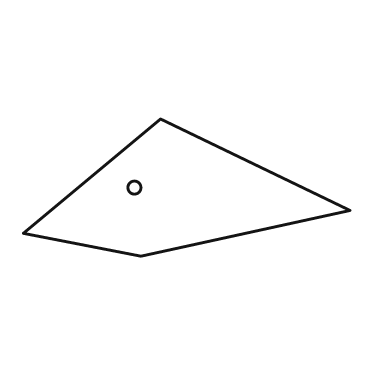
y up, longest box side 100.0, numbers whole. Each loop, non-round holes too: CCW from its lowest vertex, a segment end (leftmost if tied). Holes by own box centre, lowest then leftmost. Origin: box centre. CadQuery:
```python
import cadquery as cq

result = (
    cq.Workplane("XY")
    .moveTo(-14.0, -21.0)
    .lineTo(50.0, -7.0)
    .lineTo(-8.0, 21.0)
    .lineTo(-50.0, -14.0)
    .close()
    .moveTo(-16.0, 0.0)
    .circle(2.0)
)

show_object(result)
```